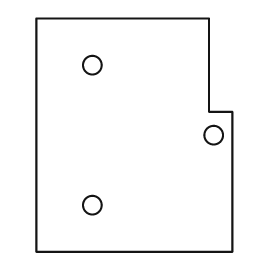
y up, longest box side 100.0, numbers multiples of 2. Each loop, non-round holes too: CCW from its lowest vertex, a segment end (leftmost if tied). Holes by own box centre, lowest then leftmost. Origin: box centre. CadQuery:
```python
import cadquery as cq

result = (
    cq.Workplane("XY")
    .moveTo(-42.0, -50.0)
    .lineTo(42.0, -50.0)
    .lineTo(42.0, 10.0)
    .lineTo(32.0, 10.0)
    .lineTo(32.0, 50.0)
    .lineTo(-42.0, 50.0)
    .close()
    .moveTo(-18.0, -30.0)
    .circle(4.0)
    .moveTo(34.0, 0.0)
    .circle(4.0)
    .moveTo(-18.0, 30.0)
    .circle(4.0)
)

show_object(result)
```